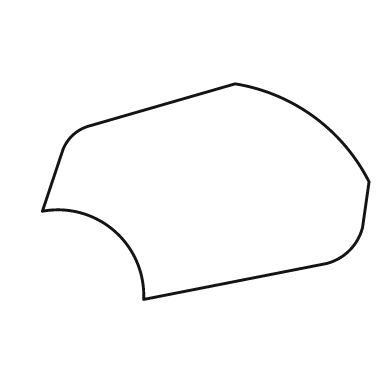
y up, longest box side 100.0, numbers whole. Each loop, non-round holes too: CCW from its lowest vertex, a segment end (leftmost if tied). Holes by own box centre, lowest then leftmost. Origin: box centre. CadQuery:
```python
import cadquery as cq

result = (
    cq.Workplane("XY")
    .moveTo(-19.0, -33.0)
    .lineTo(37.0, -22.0)
    .threePointArc((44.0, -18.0), (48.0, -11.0))
    .lineTo(50.0, 3.0)
    .threePointArc((33.0, 23.0), (9.0, 33.0))
    .lineTo(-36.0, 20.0)
    .threePointArc((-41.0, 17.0), (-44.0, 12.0))
    .lineTo(-50.0, -6.0)
    .threePointArc((-28.0, -12.0), (-19.0, -33.0))
    .close()
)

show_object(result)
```